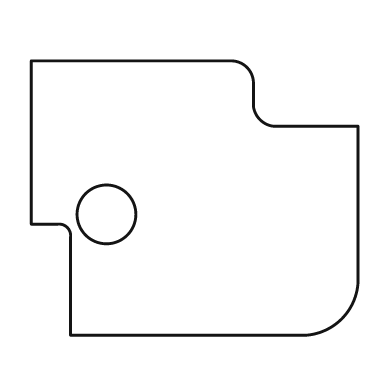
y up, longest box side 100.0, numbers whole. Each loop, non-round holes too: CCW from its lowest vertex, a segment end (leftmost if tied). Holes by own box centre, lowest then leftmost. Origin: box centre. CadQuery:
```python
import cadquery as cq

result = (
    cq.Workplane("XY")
    .moveTo(-38.0, -42.0)
    .lineTo(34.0, -42.0)
    .threePointArc((45.0, -37.0), (50.0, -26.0))
    .lineTo(50.0, 22.0)
    .lineTo(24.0, 22.0)
    .threePointArc((20.0, 24.0), (18.0, 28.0))
    .lineTo(18.0, 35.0)
    .threePointArc((16.0, 40.0), (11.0, 42.0))
    .lineTo(-50.0, 42.0)
    .lineTo(-50.0, -8.0)
    .lineTo(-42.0, -8.0)
    .threePointArc((-39.0, -9.0), (-38.0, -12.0))
    .close()
    .moveTo(-27.0, -5.0)
    .circle(9.0)
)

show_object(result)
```